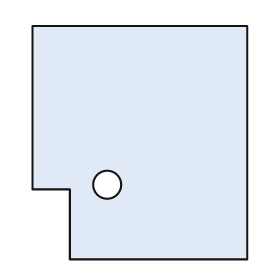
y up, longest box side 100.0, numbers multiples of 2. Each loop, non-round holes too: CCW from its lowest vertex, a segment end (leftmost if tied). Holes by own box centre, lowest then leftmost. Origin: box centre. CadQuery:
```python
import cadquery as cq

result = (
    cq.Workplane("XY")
    .moveTo(-30.0, -50.0)
    .lineTo(46.0, -50.0)
    .lineTo(46.0, 50.0)
    .lineTo(-46.0, 50.0)
    .lineTo(-46.0, -20.0)
    .lineTo(-30.0, -20.0)
    .close()
    .moveTo(-14.0, -18.0)
    .circle(6.0)
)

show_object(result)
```